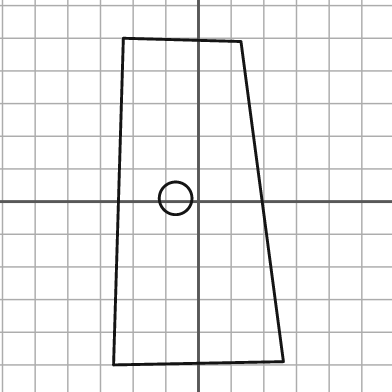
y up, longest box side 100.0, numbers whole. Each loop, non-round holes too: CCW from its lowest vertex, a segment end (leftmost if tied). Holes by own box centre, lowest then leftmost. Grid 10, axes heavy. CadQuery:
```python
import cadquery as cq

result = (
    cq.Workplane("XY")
    .moveTo(-26.0, -50.0)
    .lineTo(26.0, -49.0)
    .lineTo(13.0, 49.0)
    .lineTo(-23.0, 50.0)
    .close()
    .moveTo(-7.0, 1.0)
    .circle(5.0)
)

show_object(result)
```